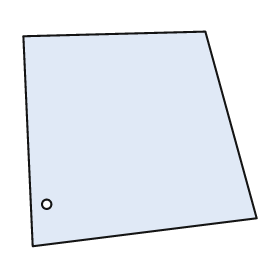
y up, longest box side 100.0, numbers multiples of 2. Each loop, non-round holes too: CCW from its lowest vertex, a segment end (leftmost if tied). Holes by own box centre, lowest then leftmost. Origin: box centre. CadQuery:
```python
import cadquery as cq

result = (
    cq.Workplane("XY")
    .moveTo(-46.0, -46.0)
    .lineTo(50.0, -34.0)
    .lineTo(28.0, 46.0)
    .lineTo(-50.0, 44.0)
    .close()
    .moveTo(-40.0, -28.0)
    .circle(2.0)
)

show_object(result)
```